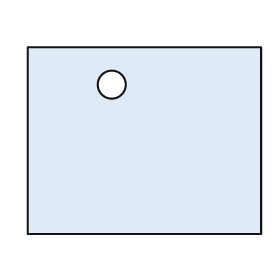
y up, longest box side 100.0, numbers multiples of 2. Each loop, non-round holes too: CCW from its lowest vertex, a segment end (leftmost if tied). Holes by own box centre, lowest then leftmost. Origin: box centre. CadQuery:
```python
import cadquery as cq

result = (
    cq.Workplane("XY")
    .moveTo(-50.0, -40.0)
    .lineTo(50.0, -40.0)
    .lineTo(50.0, 40.0)
    .lineTo(-50.0, 40.0)
    .close()
    .moveTo(-14.0, 24.0)
    .circle(6.0)
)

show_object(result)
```